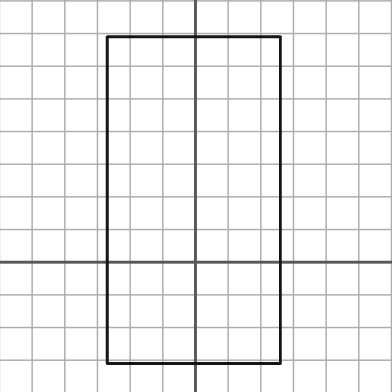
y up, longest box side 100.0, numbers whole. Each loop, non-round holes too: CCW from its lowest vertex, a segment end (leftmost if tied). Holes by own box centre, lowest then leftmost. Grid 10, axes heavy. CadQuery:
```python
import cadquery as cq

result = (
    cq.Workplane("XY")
    .moveTo(-27.0, -31.0)
    .lineTo(26.0, -31.0)
    .lineTo(26.0, 69.0)
    .lineTo(-27.0, 69.0)
    .close()
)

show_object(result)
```